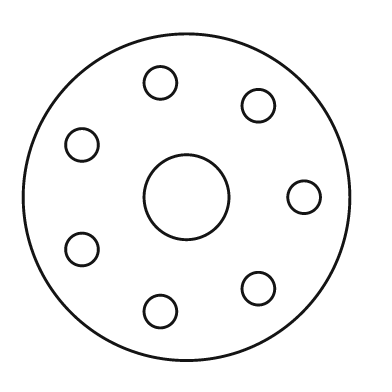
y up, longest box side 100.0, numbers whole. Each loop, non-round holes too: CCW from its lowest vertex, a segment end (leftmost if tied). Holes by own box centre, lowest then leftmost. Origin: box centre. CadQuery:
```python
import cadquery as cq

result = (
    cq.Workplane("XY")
    .moveTo(0.0, 0.0)
    .circle(50.0)
    .moveTo(-8.0, -35.0)
    .circle(5.0)
    .moveTo(22.0, -28.0)
    .circle(5.0)
    .moveTo(-32.0, -16.0)
    .circle(5.0)
    .moveTo(0.0, 0.0)
    .circle(13.0)
    .moveTo(36.0, 0.0)
    .circle(5.0)
    .moveTo(-32.0, 16.0)
    .circle(5.0)
    .moveTo(22.0, 28.0)
    .circle(5.0)
    .moveTo(-8.0, 35.0)
    .circle(5.0)
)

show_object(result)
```